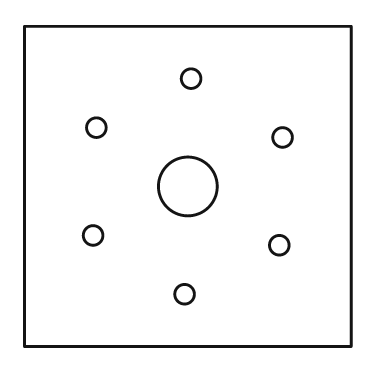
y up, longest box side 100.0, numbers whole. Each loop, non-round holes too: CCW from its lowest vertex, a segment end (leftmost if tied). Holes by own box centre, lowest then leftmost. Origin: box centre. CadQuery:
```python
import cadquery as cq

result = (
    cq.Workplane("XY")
    .moveTo(-50.0, -49.0)
    .lineTo(50.0, -49.0)
    .lineTo(50.0, 49.0)
    .lineTo(-50.0, 49.0)
    .close()
    .moveTo(-1.0, -33.0)
    .circle(3.0)
    .moveTo(28.0, -18.0)
    .circle(3.0)
    .moveTo(-29.0, -15.0)
    .circle(3.0)
    .moveTo(0.0, 0.0)
    .circle(9.0)
    .moveTo(29.0, 15.0)
    .circle(3.0)
    .moveTo(-28.0, 18.0)
    .circle(3.0)
    .moveTo(1.0, 33.0)
    .circle(3.0)
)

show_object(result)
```